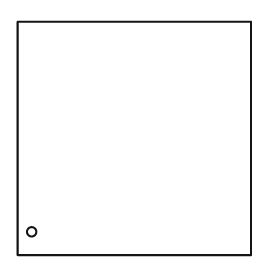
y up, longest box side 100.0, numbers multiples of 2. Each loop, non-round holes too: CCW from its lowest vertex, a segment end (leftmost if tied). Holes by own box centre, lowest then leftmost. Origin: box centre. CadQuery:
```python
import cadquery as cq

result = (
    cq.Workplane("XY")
    .moveTo(-50.0, -50.0)
    .lineTo(50.0, -50.0)
    .lineTo(50.0, 50.0)
    .lineTo(-50.0, 50.0)
    .close()
    .moveTo(-44.0, -40.0)
    .circle(2.0)
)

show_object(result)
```